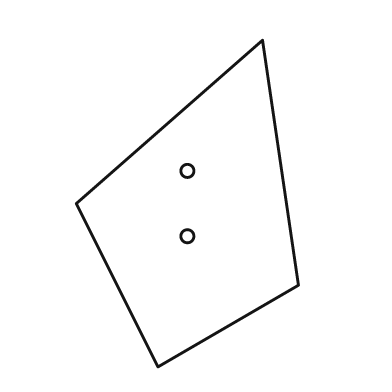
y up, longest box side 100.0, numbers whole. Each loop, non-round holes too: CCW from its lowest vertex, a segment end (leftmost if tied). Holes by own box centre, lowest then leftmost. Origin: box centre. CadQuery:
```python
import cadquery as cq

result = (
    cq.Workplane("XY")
    .moveTo(-9.0, -50.0)
    .lineTo(34.0, -25.0)
    .lineTo(23.0, 50.0)
    .lineTo(-34.0, 0.0)
    .close()
    .moveTo(0.0, -10.0)
    .circle(2.0)
    .moveTo(0.0, 10.0)
    .circle(2.0)
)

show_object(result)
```